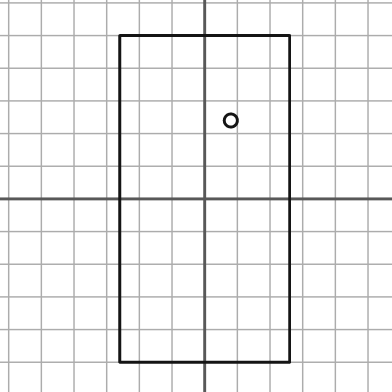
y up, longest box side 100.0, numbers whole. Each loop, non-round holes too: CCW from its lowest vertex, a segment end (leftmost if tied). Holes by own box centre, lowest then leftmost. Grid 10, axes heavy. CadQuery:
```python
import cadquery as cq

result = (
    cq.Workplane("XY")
    .moveTo(-26.0, -50.0)
    .lineTo(26.0, -50.0)
    .lineTo(26.0, 50.0)
    .lineTo(-26.0, 50.0)
    .close()
    .moveTo(8.0, 24.0)
    .circle(2.0)
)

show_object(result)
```